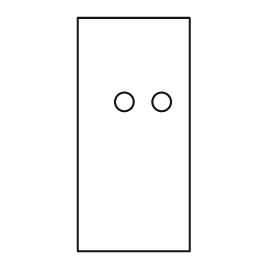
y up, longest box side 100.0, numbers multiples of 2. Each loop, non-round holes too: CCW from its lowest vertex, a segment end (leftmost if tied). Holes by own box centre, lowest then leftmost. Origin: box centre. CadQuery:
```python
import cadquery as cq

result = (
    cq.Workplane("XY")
    .moveTo(-24.0, -50.0)
    .lineTo(24.0, -50.0)
    .lineTo(24.0, 50.0)
    .lineTo(-24.0, 50.0)
    .close()
    .moveTo(-4.0, 14.0)
    .circle(4.0)
    .moveTo(12.0, 14.0)
    .circle(4.0)
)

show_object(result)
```